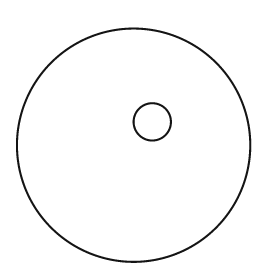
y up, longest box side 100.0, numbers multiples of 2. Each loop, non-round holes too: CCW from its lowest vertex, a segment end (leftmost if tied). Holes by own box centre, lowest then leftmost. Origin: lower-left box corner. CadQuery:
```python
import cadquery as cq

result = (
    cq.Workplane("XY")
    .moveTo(50.0, 50.0)
    .circle(50.0)
    .moveTo(58.0, 60.0)
    .circle(8.0)
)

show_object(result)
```